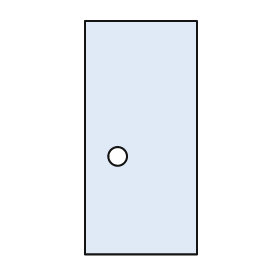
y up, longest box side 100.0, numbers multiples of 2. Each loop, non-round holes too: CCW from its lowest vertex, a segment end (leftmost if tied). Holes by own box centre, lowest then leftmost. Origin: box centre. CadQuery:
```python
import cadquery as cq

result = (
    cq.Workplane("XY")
    .moveTo(-24.0, -50.0)
    .lineTo(24.0, -50.0)
    .lineTo(24.0, 50.0)
    .lineTo(-24.0, 50.0)
    .close()
    .moveTo(-10.0, -8.0)
    .circle(4.0)
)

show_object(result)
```